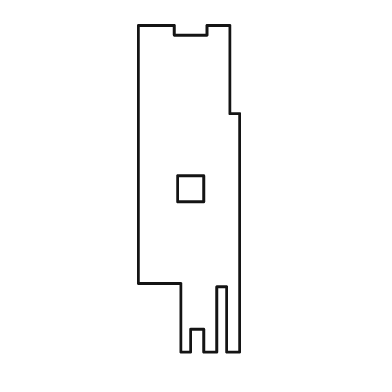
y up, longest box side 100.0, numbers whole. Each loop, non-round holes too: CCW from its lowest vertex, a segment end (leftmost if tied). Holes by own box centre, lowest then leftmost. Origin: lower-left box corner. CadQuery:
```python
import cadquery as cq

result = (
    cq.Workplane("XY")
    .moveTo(13.0, 0.0)
    .lineTo(16.0, 0.0)
    .lineTo(16.0, 7.0)
    .lineTo(20.0, 7.0)
    .lineTo(20.0, 0.0)
    .lineTo(24.0, 0.0)
    .lineTo(24.0, 20.0)
    .lineTo(27.0, 20.0)
    .lineTo(27.0, 0.0)
    .lineTo(31.0, 0.0)
    .lineTo(31.0, 73.0)
    .lineTo(28.0, 73.0)
    .lineTo(28.0, 100.0)
    .lineTo(21.0, 100.0)
    .lineTo(21.0, 97.0)
    .lineTo(11.0, 97.0)
    .lineTo(11.0, 100.0)
    .lineTo(0.0, 100.0)
    .lineTo(0.0, 21.0)
    .lineTo(13.0, 21.0)
    .close()
    .moveTo(12.0, 46.0)
    .lineTo(20.0, 46.0)
    .lineTo(20.0, 54.0)
    .lineTo(12.0, 54.0)
    .close()
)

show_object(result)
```